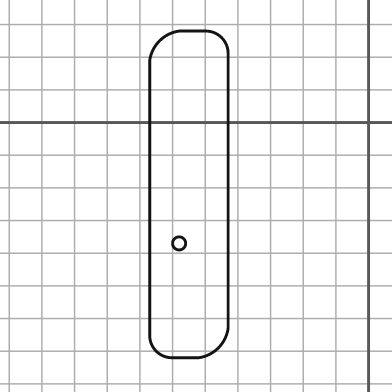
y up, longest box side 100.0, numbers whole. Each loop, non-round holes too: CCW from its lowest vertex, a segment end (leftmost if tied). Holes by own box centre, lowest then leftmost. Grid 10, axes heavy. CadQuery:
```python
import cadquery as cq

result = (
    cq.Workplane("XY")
    .moveTo(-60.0, -72.0)
    .lineTo(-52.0, -72.0)
    .threePointArc((-46.0, -69.0), (-43.0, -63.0))
    .lineTo(-43.0, 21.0)
    .threePointArc((-45.0, 26.0), (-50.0, 28.0))
    .lineTo(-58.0, 28.0)
    .threePointArc((-64.0, 25.0), (-67.0, 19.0))
    .lineTo(-67.0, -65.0)
    .threePointArc((-65.0, -70.0), (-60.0, -72.0))
    .close()
    .moveTo(-58.0, -37.0)
    .circle(2.0)
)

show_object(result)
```